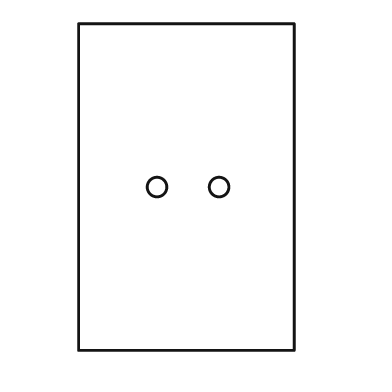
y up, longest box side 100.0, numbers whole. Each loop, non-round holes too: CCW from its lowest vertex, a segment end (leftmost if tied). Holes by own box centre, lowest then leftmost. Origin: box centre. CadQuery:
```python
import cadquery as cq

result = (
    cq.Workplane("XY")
    .moveTo(-33.0, -50.0)
    .lineTo(33.0, -50.0)
    .lineTo(33.0, 50.0)
    .lineTo(-33.0, 50.0)
    .close()
    .moveTo(-9.0, 0.0)
    .circle(3.0)
    .moveTo(10.0, 0.0)
    .circle(3.0)
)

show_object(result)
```